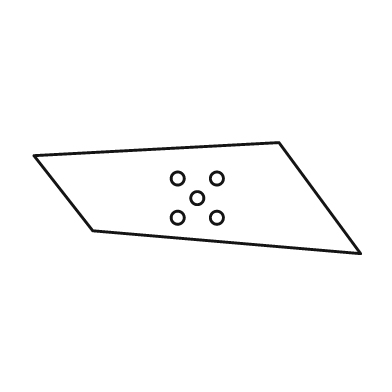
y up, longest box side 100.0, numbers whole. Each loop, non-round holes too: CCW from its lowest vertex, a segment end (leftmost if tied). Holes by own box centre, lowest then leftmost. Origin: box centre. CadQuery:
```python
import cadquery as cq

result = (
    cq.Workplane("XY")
    .moveTo(50.0, -17.0)
    .lineTo(25.0, 17.0)
    .lineTo(-50.0, 13.0)
    .lineTo(-32.0, -10.0)
    .close()
    .moveTo(-6.0, -6.0)
    .circle(2.0)
    .moveTo(6.0, -6.0)
    .circle(2.0)
    .moveTo(0.0, 0.0)
    .circle(2.0)
    .moveTo(-6.0, 6.0)
    .circle(2.0)
    .moveTo(6.0, 6.0)
    .circle(2.0)
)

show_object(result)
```